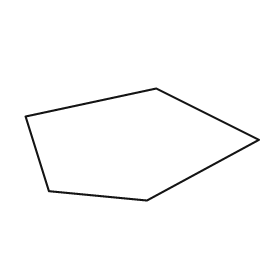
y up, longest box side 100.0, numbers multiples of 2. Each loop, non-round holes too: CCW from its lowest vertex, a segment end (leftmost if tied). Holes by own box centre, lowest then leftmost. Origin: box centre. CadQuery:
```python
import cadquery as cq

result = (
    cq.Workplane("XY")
    .moveTo(2.0, -24.0)
    .lineTo(50.0, 2.0)
    .lineTo(6.0, 24.0)
    .lineTo(-50.0, 12.0)
    .lineTo(-40.0, -20.0)
    .close()
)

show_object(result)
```